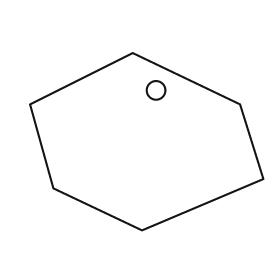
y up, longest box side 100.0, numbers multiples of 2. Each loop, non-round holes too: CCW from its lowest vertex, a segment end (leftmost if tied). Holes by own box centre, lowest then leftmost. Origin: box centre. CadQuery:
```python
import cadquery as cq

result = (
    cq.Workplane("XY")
    .moveTo(-2.0, -38.0)
    .lineTo(50.0, -16.0)
    .lineTo(40.0, 16.0)
    .lineTo(-6.0, 38.0)
    .lineTo(-50.0, 16.0)
    .lineTo(-40.0, -20.0)
    .close()
    .moveTo(4.0, 22.0)
    .circle(4.0)
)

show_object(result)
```